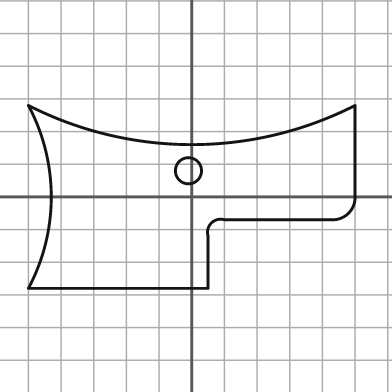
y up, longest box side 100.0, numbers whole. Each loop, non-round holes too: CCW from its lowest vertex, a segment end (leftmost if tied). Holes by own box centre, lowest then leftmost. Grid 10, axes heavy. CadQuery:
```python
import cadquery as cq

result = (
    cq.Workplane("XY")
    .moveTo(-50.0, -28.0)
    .lineTo(5.0, -28.0)
    .lineTo(5.0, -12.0)
    .threePointArc((6.0, -8.0), (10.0, -7.0))
    .lineTo(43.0, -7.0)
    .threePointArc((48.0, -5.0), (50.0, 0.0))
    .lineTo(50.0, 28.0)
    .threePointArc((0.0, 16.0), (-50.0, 28.0))
    .threePointArc((-43.0, 0.0), (-50.0, -28.0))
    .close()
    .moveTo(-1.0, 8.0)
    .circle(4.0)
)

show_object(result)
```